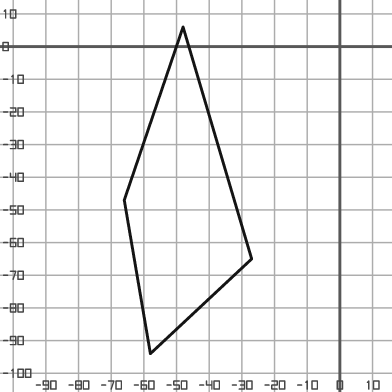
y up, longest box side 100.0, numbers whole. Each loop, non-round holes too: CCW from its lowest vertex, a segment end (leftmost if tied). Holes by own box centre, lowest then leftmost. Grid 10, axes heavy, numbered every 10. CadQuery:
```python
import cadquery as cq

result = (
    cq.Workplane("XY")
    .moveTo(-58.0, -94.0)
    .lineTo(-27.0, -65.0)
    .lineTo(-48.0, 6.0)
    .lineTo(-66.0, -47.0)
    .close()
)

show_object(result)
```